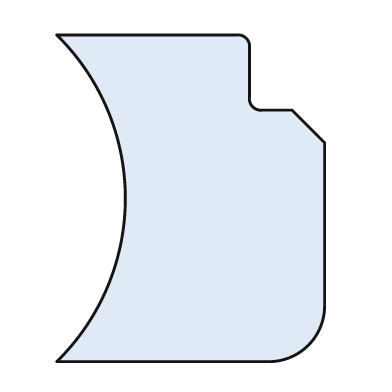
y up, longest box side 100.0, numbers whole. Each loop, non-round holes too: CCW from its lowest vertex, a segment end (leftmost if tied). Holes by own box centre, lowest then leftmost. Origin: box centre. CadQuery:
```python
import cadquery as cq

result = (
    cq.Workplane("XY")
    .moveTo(-41.0, -50.0)
    .lineTo(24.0, -50.0)
    .threePointArc((36.0, -45.0), (41.0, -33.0))
    .lineTo(41.0, 17.0)
    .lineTo(31.0, 27.0)
    .lineTo(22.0, 27.0)
    .threePointArc((19.0, 28.0), (18.0, 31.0))
    .lineTo(18.0, 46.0)
    .threePointArc((17.0, 49.0), (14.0, 50.0))
    .lineTo(-41.0, 50.0)
    .threePointArc((-20.0, 0.0), (-41.0, -50.0))
    .close()
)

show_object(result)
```